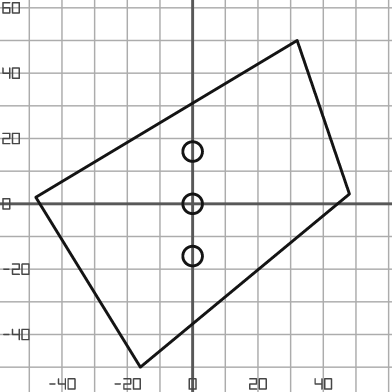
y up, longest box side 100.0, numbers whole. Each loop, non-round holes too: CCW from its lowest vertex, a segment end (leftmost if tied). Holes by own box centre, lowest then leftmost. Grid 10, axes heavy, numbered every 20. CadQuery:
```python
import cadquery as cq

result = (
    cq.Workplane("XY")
    .moveTo(-16.0, -50.0)
    .lineTo(48.0, 3.0)
    .lineTo(32.0, 50.0)
    .lineTo(-48.0, 2.0)
    .close()
    .moveTo(0.0, -16.0)
    .circle(3.0)
    .moveTo(0.0, 0.0)
    .circle(3.0)
    .moveTo(0.0, 16.0)
    .circle(3.0)
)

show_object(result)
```